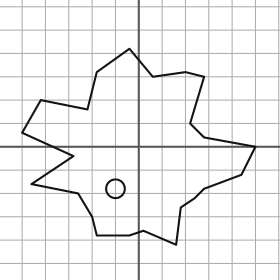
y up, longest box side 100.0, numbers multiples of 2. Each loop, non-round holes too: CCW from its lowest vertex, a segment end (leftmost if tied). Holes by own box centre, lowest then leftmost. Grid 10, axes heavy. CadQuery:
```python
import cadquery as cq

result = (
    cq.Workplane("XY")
    .moveTo(16.0, -42.0)
    .lineTo(18.0, -26.0)
    .lineTo(24.0, -22.0)
    .lineTo(28.0, -18.0)
    .lineTo(44.0, -12.0)
    .lineTo(50.0, 0.0)
    .lineTo(28.0, 4.0)
    .lineTo(22.0, 10.0)
    .lineTo(28.0, 30.0)
    .lineTo(20.0, 32.0)
    .lineTo(6.0, 30.0)
    .lineTo(-4.0, 42.0)
    .lineTo(-18.0, 32.0)
    .lineTo(-22.0, 16.0)
    .lineTo(-42.0, 20.0)
    .lineTo(-50.0, 6.0)
    .lineTo(-28.0, -4.0)
    .lineTo(-46.0, -16.0)
    .lineTo(-26.0, -20.0)
    .lineTo(-20.0, -30.0)
    .lineTo(-18.0, -38.0)
    .lineTo(-4.0, -38.0)
    .lineTo(2.0, -36.0)
    .close()
    .moveTo(-10.0, -18.0)
    .circle(4.0)
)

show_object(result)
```